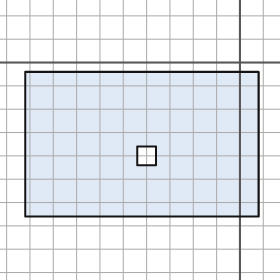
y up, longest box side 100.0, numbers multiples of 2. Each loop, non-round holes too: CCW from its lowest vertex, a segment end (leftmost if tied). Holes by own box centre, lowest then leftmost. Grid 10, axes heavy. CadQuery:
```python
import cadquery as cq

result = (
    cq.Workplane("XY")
    .moveTo(-92.0, -66.0)
    .lineTo(8.0, -66.0)
    .lineTo(8.0, -4.0)
    .lineTo(-92.0, -4.0)
    .close()
    .moveTo(-44.0, -44.0)
    .lineTo(-36.0, -44.0)
    .lineTo(-36.0, -36.0)
    .lineTo(-44.0, -36.0)
    .close()
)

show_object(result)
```